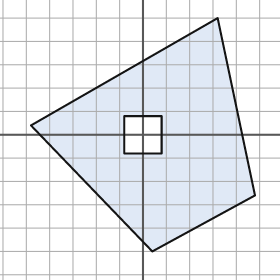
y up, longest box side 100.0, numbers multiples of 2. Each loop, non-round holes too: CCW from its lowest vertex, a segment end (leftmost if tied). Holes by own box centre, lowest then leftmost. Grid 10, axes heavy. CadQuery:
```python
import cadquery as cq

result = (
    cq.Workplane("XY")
    .moveTo(4.0, -50.0)
    .lineTo(48.0, -26.0)
    .lineTo(32.0, 50.0)
    .lineTo(-48.0, 4.0)
    .close()
    .moveTo(-8.0, -8.0)
    .lineTo(8.0, -8.0)
    .lineTo(8.0, 8.0)
    .lineTo(-8.0, 8.0)
    .close()
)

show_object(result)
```